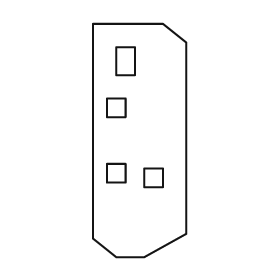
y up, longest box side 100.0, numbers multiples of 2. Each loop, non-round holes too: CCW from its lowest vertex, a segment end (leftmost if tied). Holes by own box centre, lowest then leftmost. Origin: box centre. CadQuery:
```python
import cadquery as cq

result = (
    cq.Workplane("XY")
    .moveTo(-10.0, -50.0)
    .lineTo(2.0, -50.0)
    .lineTo(20.0, -40.0)
    .lineTo(20.0, 42.0)
    .lineTo(10.0, 50.0)
    .lineTo(-20.0, 50.0)
    .lineTo(-20.0, -42.0)
    .close()
    .moveTo(2.0, -20.0)
    .lineTo(10.0, -20.0)
    .lineTo(10.0, -12.0)
    .lineTo(2.0, -12.0)
    .close()
    .moveTo(-14.0, -18.0)
    .lineTo(-6.0, -18.0)
    .lineTo(-6.0, -10.0)
    .lineTo(-14.0, -10.0)
    .close()
    .moveTo(-14.0, 10.0)
    .lineTo(-6.0, 10.0)
    .lineTo(-6.0, 18.0)
    .lineTo(-14.0, 18.0)
    .close()
    .moveTo(-10.0, 28.0)
    .lineTo(-2.0, 28.0)
    .lineTo(-2.0, 40.0)
    .lineTo(-10.0, 40.0)
    .close()
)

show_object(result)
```